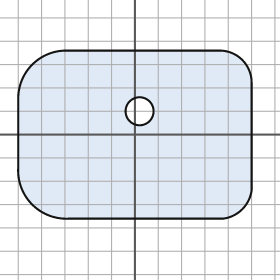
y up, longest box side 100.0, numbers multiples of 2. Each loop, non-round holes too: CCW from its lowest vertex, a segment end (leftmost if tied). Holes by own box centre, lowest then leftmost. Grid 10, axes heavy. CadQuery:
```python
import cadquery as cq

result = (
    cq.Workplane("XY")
    .moveTo(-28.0, -36.0)
    .lineTo(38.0, -36.0)
    .threePointArc((46.0, -32.0), (50.0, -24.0))
    .lineTo(50.0, 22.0)
    .threePointArc((46.0, 32.0), (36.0, 36.0))
    .lineTo(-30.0, 36.0)
    .threePointArc((-44.0, 30.0), (-50.0, 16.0))
    .lineTo(-50.0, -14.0)
    .threePointArc((-44.0, -30.0), (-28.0, -36.0))
    .close()
    .moveTo(2.0, 10.0)
    .circle(6.0)
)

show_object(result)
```